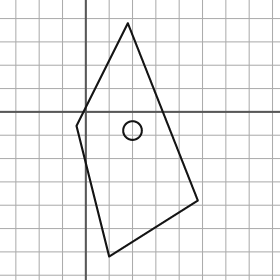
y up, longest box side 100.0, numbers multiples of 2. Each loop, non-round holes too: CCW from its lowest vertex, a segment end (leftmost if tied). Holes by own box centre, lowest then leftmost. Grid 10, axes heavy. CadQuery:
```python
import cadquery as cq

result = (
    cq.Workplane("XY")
    .moveTo(10.0, -62.0)
    .lineTo(48.0, -38.0)
    .lineTo(18.0, 38.0)
    .lineTo(-4.0, -6.0)
    .close()
    .moveTo(20.0, -8.0)
    .circle(4.0)
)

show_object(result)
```